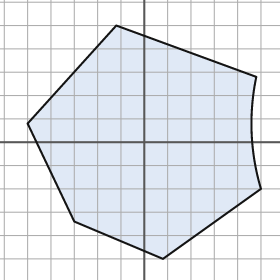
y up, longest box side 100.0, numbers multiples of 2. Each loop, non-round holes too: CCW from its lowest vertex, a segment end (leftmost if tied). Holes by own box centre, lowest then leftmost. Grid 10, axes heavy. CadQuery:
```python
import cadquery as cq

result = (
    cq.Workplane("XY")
    .moveTo(8.0, -50.0)
    .lineTo(50.0, -20.0)
    .threePointArc((46.0, 4.0), (48.0, 28.0))
    .lineTo(-12.0, 50.0)
    .lineTo(-50.0, 8.0)
    .lineTo(-30.0, -34.0)
    .close()
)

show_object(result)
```